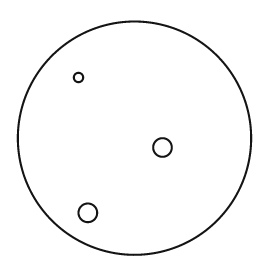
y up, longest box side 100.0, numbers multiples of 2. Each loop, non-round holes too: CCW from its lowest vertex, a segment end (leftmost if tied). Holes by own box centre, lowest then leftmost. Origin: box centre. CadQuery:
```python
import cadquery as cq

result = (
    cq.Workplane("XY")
    .moveTo(0.0, 0.0)
    .circle(50.0)
    .moveTo(-20.0, -32.0)
    .circle(4.0)
    .moveTo(12.0, -4.0)
    .circle(4.0)
    .moveTo(-24.0, 26.0)
    .circle(2.0)
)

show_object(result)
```